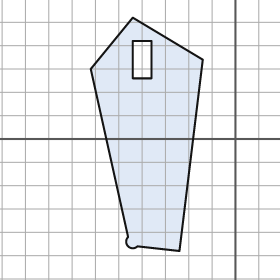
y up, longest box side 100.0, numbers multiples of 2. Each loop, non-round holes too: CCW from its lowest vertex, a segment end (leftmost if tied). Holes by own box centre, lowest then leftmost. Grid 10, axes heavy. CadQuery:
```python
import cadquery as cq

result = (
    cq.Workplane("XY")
    .moveTo(-24.0, -48.0)
    .lineTo(-14.0, 34.0)
    .lineTo(-44.0, 52.0)
    .lineTo(-62.0, 30.0)
    .lineTo(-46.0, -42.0)
    .threePointArc((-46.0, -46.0), (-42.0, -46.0))
    .close()
    .moveTo(-44.0, 26.0)
    .lineTo(-36.0, 26.0)
    .lineTo(-36.0, 42.0)
    .lineTo(-44.0, 42.0)
    .close()
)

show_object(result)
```